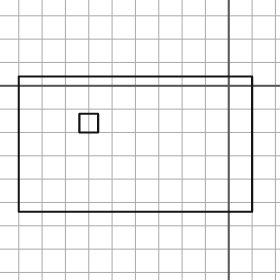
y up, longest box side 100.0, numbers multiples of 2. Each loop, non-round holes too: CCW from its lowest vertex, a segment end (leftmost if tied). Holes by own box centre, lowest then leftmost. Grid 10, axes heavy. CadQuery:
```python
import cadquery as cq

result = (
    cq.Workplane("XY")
    .moveTo(-90.0, -54.0)
    .lineTo(10.0, -54.0)
    .lineTo(10.0, 4.0)
    .lineTo(-90.0, 4.0)
    .close()
    .moveTo(-64.0, -20.0)
    .lineTo(-56.0, -20.0)
    .lineTo(-56.0, -12.0)
    .lineTo(-64.0, -12.0)
    .close()
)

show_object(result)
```